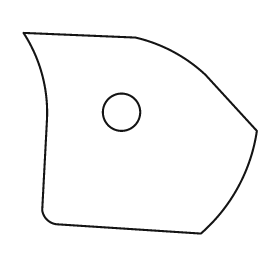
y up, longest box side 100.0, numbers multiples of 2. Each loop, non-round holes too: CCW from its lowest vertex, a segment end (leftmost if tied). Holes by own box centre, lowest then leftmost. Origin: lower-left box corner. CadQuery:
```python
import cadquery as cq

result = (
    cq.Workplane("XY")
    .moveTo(76.0, 0.0)
    .threePointArc((92.0, 20.0), (100.0, 44.0))
    .lineTo(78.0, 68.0)
    .threePointArc((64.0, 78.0), (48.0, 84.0))
    .lineTo(0.0, 86.0)
    .threePointArc((8.0, 68.0), (10.0, 48.0))
    .lineTo(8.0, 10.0)
    .threePointArc((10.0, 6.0), (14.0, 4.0))
    .close()
    .moveTo(42.0, 52.0)
    .circle(8.0)
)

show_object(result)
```